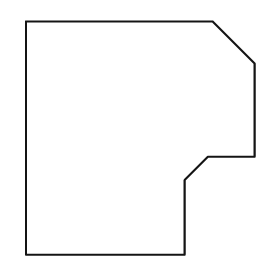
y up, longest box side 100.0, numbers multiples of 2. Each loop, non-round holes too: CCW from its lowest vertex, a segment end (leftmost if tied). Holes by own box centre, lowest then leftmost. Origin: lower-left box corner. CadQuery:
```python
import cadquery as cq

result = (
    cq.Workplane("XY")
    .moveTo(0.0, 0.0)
    .lineTo(68.0, 0.0)
    .lineTo(68.0, 32.0)
    .lineTo(78.0, 42.0)
    .lineTo(98.0, 42.0)
    .lineTo(98.0, 82.0)
    .lineTo(80.0, 100.0)
    .lineTo(0.0, 100.0)
    .close()
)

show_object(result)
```